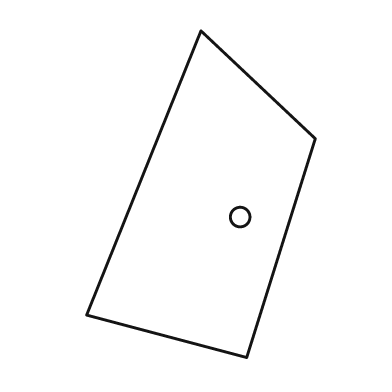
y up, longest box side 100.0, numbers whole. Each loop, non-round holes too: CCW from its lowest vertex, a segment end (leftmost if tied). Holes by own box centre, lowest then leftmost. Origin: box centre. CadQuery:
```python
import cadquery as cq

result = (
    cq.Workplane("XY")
    .moveTo(14.0, -50.0)
    .lineTo(35.0, 17.0)
    .lineTo(0.0, 50.0)
    .lineTo(-35.0, -37.0)
    .close()
    .moveTo(12.0, -7.0)
    .circle(3.0)
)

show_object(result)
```